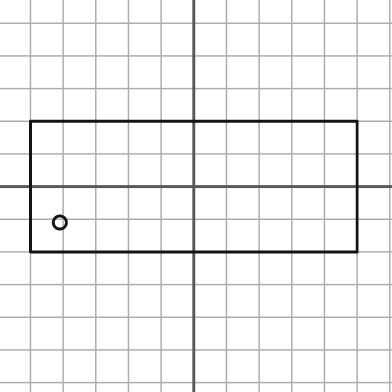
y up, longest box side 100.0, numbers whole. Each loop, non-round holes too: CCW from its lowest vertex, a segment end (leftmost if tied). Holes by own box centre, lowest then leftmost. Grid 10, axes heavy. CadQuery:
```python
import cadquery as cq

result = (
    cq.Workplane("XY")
    .moveTo(-50.0, -20.0)
    .lineTo(50.0, -20.0)
    .lineTo(50.0, 20.0)
    .lineTo(-50.0, 20.0)
    .close()
    .moveTo(-41.0, -11.0)
    .circle(2.0)
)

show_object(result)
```